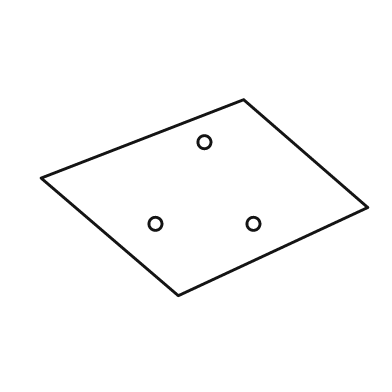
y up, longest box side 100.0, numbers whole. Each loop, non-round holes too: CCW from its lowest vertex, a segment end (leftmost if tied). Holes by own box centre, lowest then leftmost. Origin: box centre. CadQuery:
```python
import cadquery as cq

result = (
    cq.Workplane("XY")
    .moveTo(-8.0, -30.0)
    .lineTo(50.0, -3.0)
    .lineTo(12.0, 30.0)
    .lineTo(-50.0, 6.0)
    .close()
    .moveTo(-15.0, -8.0)
    .circle(2.0)
    .moveTo(15.0, -8.0)
    .circle(2.0)
    .moveTo(0.0, 17.0)
    .circle(2.0)
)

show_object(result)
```